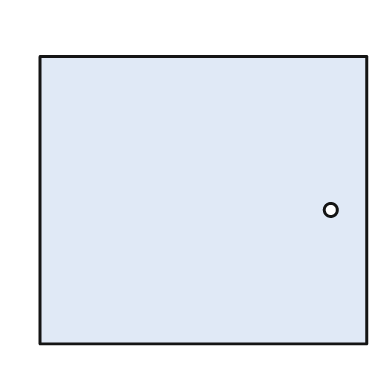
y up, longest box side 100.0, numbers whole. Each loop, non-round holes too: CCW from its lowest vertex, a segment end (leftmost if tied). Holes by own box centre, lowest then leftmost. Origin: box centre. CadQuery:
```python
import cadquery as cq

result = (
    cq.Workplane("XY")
    .moveTo(-50.0, -44.0)
    .lineTo(50.0, -44.0)
    .lineTo(50.0, 44.0)
    .lineTo(-50.0, 44.0)
    .close()
    .moveTo(39.0, -3.0)
    .circle(2.0)
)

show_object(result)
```